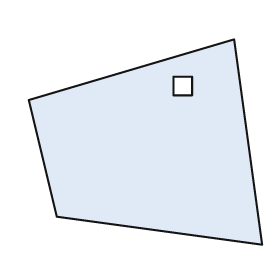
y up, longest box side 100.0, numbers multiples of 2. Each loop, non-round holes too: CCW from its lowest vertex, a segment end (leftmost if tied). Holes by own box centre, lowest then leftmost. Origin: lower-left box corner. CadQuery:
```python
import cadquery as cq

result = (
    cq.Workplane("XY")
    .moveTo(100.0, 0.0)
    .lineTo(88.0, 88.0)
    .lineTo(0.0, 62.0)
    .lineTo(12.0, 12.0)
    .close()
    .moveTo(62.0, 64.0)
    .lineTo(70.0, 64.0)
    .lineTo(70.0, 72.0)
    .lineTo(62.0, 72.0)
    .close()
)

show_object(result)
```